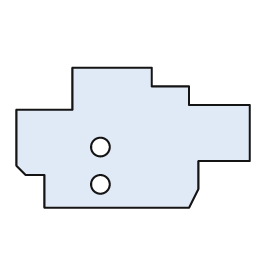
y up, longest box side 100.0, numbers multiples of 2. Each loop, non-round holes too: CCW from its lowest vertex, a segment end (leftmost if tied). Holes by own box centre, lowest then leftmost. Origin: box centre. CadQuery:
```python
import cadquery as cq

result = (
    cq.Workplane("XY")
    .moveTo(-38.0, -30.0)
    .lineTo(24.0, -30.0)
    .lineTo(28.0, -22.0)
    .lineTo(28.0, -10.0)
    .lineTo(50.0, -10.0)
    .lineTo(50.0, 14.0)
    .lineTo(24.0, 14.0)
    .lineTo(24.0, 22.0)
    .lineTo(8.0, 22.0)
    .lineTo(8.0, 30.0)
    .lineTo(-26.0, 30.0)
    .lineTo(-26.0, 12.0)
    .lineTo(-50.0, 12.0)
    .lineTo(-50.0, -12.0)
    .lineTo(-46.0, -16.0)
    .lineTo(-38.0, -16.0)
    .close()
    .moveTo(-14.0, -20.0)
    .circle(4.0)
    .moveTo(-14.0, -4.0)
    .circle(4.0)
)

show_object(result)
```